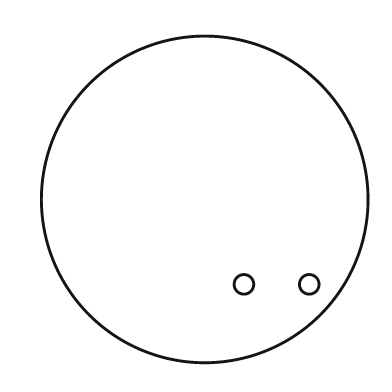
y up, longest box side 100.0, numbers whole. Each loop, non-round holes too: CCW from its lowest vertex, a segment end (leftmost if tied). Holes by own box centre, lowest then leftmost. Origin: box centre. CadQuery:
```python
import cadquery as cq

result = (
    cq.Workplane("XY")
    .moveTo(0.0, 0.0)
    .circle(50.0)
    .moveTo(12.0, -26.0)
    .circle(3.0)
    .moveTo(32.0, -26.0)
    .circle(3.0)
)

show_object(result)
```